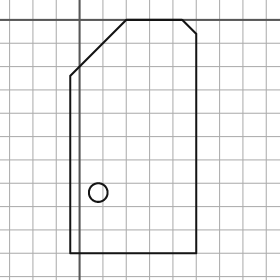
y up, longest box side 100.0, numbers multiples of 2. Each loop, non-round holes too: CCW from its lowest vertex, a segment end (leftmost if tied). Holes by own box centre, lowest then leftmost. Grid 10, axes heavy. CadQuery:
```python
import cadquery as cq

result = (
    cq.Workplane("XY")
    .moveTo(-4.0, -100.0)
    .lineTo(50.0, -100.0)
    .lineTo(50.0, -6.0)
    .lineTo(44.0, 0.0)
    .lineTo(20.0, 0.0)
    .lineTo(-4.0, -24.0)
    .close()
    .moveTo(8.0, -74.0)
    .circle(4.0)
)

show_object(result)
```